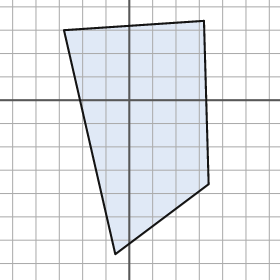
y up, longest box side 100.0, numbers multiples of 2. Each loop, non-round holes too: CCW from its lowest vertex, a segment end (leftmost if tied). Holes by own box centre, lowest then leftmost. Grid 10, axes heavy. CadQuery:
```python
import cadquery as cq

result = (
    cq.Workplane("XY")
    .moveTo(-6.0, -66.0)
    .lineTo(34.0, -36.0)
    .lineTo(32.0, 34.0)
    .lineTo(-28.0, 30.0)
    .close()
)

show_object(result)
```